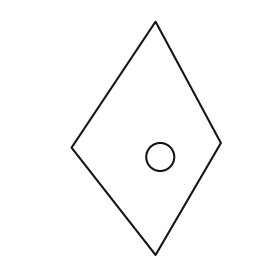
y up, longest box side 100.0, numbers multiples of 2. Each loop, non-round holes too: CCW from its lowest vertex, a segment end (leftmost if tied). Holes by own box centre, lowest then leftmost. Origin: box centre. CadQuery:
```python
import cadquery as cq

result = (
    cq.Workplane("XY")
    .moveTo(4.0, -50.0)
    .lineTo(32.0, -2.0)
    .lineTo(4.0, 50.0)
    .lineTo(-32.0, -4.0)
    .close()
    .moveTo(6.0, -8.0)
    .circle(6.0)
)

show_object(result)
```